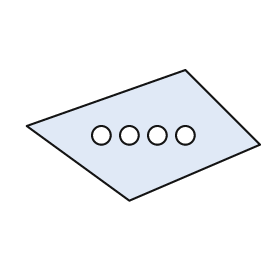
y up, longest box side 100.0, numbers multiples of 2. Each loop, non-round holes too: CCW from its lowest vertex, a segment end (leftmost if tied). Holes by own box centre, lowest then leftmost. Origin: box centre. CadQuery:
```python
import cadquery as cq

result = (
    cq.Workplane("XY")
    .moveTo(-6.0, -28.0)
    .lineTo(50.0, -4.0)
    .lineTo(18.0, 28.0)
    .lineTo(-50.0, 4.0)
    .close()
    .moveTo(-18.0, 0.0)
    .circle(4.0)
    .moveTo(-6.0, 0.0)
    .circle(4.0)
    .moveTo(6.0, 0.0)
    .circle(4.0)
    .moveTo(18.0, 0.0)
    .circle(4.0)
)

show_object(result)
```